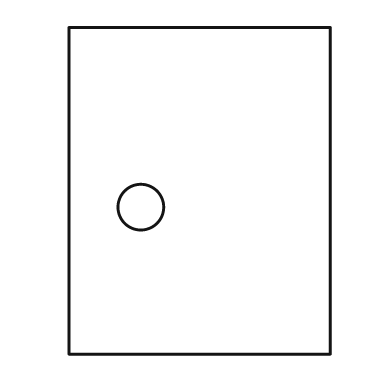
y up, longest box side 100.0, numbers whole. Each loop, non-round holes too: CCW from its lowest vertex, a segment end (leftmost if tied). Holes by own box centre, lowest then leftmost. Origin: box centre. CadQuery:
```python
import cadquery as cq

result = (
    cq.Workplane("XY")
    .moveTo(-40.0, -50.0)
    .lineTo(40.0, -50.0)
    .lineTo(40.0, 50.0)
    .lineTo(-40.0, 50.0)
    .close()
    .moveTo(-18.0, -5.0)
    .circle(7.0)
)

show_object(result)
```